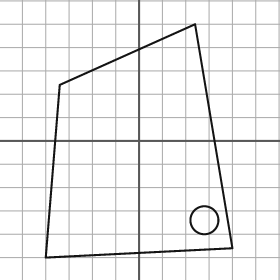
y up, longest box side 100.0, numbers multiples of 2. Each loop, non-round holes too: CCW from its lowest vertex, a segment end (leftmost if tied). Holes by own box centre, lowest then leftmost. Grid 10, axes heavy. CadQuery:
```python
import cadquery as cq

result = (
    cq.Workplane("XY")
    .moveTo(-40.0, -50.0)
    .lineTo(40.0, -46.0)
    .lineTo(24.0, 50.0)
    .lineTo(-34.0, 24.0)
    .close()
    .moveTo(28.0, -34.0)
    .circle(6.0)
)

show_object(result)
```